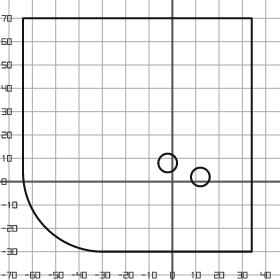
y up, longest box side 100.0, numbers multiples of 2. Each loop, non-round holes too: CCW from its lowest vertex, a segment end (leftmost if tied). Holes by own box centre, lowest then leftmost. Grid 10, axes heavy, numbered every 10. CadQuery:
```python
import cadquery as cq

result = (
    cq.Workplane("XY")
    .moveTo(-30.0, -30.0)
    .lineTo(34.0, -30.0)
    .lineTo(34.0, 70.0)
    .lineTo(-64.0, 70.0)
    .lineTo(-64.0, 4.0)
    .threePointArc((-54.0, -20.0), (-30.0, -30.0))
    .close()
    .moveTo(12.0, 2.0)
    .circle(4.0)
    .moveTo(-2.0, 8.0)
    .circle(4.0)
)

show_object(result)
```